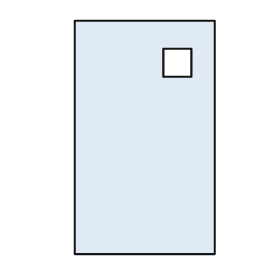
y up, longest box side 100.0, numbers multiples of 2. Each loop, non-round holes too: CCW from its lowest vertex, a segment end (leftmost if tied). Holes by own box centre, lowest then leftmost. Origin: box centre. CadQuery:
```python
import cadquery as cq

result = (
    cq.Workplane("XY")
    .moveTo(-30.0, -50.0)
    .lineTo(30.0, -50.0)
    .lineTo(30.0, 50.0)
    .lineTo(-30.0, 50.0)
    .close()
    .moveTo(8.0, 26.0)
    .lineTo(20.0, 26.0)
    .lineTo(20.0, 38.0)
    .lineTo(8.0, 38.0)
    .close()
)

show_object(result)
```